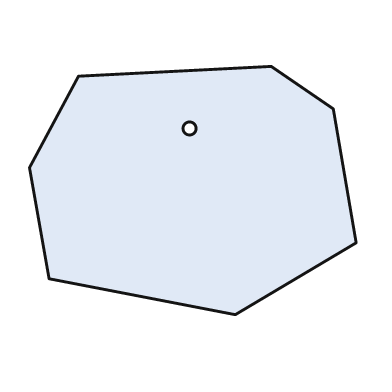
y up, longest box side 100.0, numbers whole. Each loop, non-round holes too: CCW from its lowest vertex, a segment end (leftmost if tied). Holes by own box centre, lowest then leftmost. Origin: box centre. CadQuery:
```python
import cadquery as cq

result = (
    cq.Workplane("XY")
    .moveTo(13.0, -38.0)
    .lineTo(50.0, -16.0)
    .lineTo(43.0, 25.0)
    .lineTo(24.0, 38.0)
    .lineTo(-35.0, 35.0)
    .lineTo(-50.0, 7.0)
    .lineTo(-44.0, -27.0)
    .close()
    .moveTo(-1.0, 19.0)
    .circle(2.0)
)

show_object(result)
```